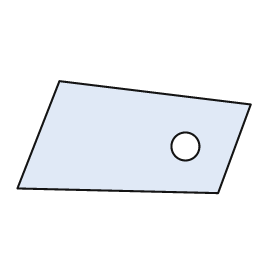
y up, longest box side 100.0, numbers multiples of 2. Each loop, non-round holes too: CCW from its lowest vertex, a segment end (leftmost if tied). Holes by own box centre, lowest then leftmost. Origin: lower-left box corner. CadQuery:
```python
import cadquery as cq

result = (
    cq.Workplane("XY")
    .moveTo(86.0, 0.0)
    .lineTo(100.0, 38.0)
    .lineTo(18.0, 48.0)
    .lineTo(0.0, 2.0)
    .close()
    .moveTo(72.0, 20.0)
    .circle(6.0)
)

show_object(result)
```